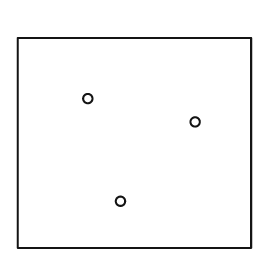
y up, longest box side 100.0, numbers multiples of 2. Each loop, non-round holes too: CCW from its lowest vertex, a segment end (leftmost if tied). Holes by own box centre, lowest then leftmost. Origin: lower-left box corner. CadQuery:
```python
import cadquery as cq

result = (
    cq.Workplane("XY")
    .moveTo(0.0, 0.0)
    .lineTo(100.0, 0.0)
    .lineTo(100.0, 90.0)
    .lineTo(0.0, 90.0)
    .close()
    .moveTo(44.0, 20.0)
    .circle(2.0)
    .moveTo(76.0, 54.0)
    .circle(2.0)
    .moveTo(30.0, 64.0)
    .circle(2.0)
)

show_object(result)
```